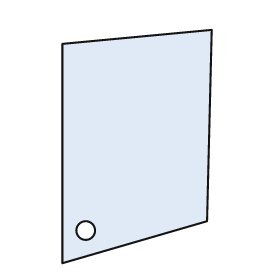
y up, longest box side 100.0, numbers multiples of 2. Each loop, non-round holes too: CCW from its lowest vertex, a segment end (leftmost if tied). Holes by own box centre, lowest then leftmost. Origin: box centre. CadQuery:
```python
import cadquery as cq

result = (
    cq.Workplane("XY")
    .moveTo(-32.0, -50.0)
    .lineTo(30.0, -32.0)
    .lineTo(32.0, 50.0)
    .lineTo(-32.0, 44.0)
    .close()
    .moveTo(-22.0, -36.0)
    .circle(4.0)
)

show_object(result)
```